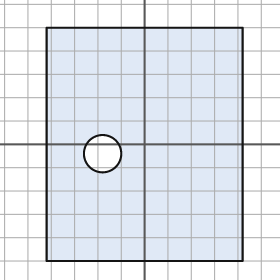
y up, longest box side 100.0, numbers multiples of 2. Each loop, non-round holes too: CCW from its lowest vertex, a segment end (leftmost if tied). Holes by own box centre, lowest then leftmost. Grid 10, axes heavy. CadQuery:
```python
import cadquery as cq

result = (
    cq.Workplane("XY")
    .moveTo(-42.0, -50.0)
    .lineTo(42.0, -50.0)
    .lineTo(42.0, 50.0)
    .lineTo(-42.0, 50.0)
    .close()
    .moveTo(-18.0, -4.0)
    .circle(8.0)
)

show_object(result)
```